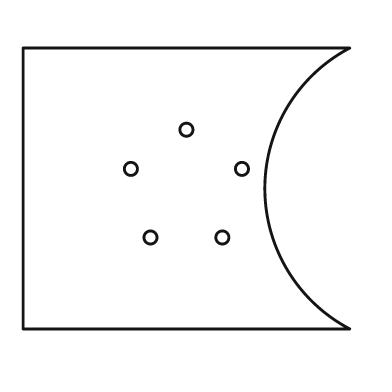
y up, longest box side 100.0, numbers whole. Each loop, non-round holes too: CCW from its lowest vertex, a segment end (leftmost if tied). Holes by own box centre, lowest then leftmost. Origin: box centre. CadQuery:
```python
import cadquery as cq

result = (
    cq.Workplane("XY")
    .moveTo(-50.0, -43.0)
    .lineTo(50.0, -43.0)
    .threePointArc((24.0, 0.0), (50.0, 43.0))
    .lineTo(-50.0, 43.0)
    .close()
    .moveTo(-11.0, -15.0)
    .circle(2.0)
    .moveTo(11.0, -15.0)
    .circle(2.0)
    .moveTo(-17.0, 6.0)
    .circle(2.0)
    .moveTo(17.0, 6.0)
    .circle(2.0)
    .moveTo(0.0, 18.0)
    .circle(2.0)
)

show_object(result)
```